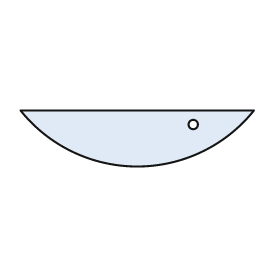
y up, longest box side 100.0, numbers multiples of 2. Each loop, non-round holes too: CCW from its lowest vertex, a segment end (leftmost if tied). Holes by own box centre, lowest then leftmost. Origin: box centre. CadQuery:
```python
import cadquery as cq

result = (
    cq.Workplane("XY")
    .moveTo(-50.0, 12.0)
    .threePointArc((0.0, -12.0), (50.0, 12.0))
    .close()
    .moveTo(24.0, 6.0)
    .circle(2.0)
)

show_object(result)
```